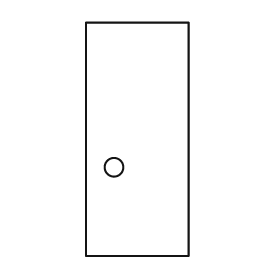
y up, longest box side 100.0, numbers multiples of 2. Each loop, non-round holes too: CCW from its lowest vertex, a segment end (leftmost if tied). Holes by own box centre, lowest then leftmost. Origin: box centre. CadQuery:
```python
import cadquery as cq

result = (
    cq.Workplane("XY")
    .moveTo(-22.0, -50.0)
    .lineTo(22.0, -50.0)
    .lineTo(22.0, 50.0)
    .lineTo(-22.0, 50.0)
    .close()
    .moveTo(-10.0, -12.0)
    .circle(4.0)
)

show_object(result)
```